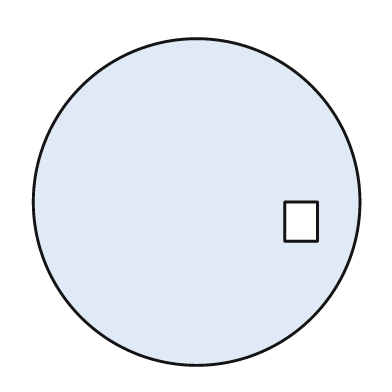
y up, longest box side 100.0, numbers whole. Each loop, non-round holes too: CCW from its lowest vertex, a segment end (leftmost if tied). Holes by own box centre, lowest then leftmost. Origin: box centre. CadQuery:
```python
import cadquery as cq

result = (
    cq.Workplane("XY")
    .moveTo(0.0, 0.0)
    .circle(50.0)
    .moveTo(27.0, -12.0)
    .lineTo(37.0, -12.0)
    .lineTo(37.0, 0.0)
    .lineTo(27.0, 0.0)
    .close()
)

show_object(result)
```